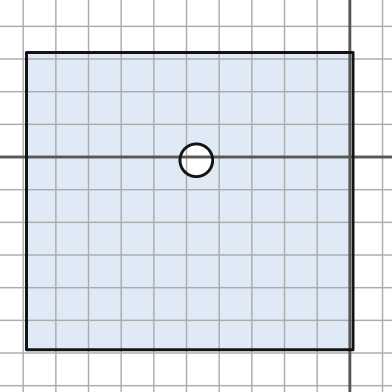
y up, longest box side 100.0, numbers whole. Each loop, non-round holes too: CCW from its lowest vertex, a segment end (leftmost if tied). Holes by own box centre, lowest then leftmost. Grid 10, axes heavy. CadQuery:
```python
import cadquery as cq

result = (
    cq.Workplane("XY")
    .moveTo(-99.0, -59.0)
    .lineTo(1.0, -59.0)
    .lineTo(1.0, 32.0)
    .lineTo(-99.0, 32.0)
    .close()
    .moveTo(-47.0, -1.0)
    .circle(5.0)
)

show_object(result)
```